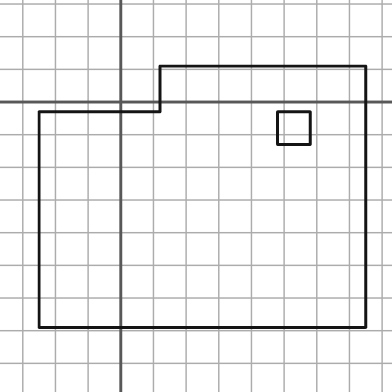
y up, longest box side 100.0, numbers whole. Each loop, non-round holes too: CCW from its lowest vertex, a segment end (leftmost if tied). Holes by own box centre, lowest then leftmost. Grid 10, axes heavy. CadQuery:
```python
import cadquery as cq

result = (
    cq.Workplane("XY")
    .moveTo(-25.0, -69.0)
    .lineTo(75.0, -69.0)
    .lineTo(75.0, 11.0)
    .lineTo(12.0, 11.0)
    .lineTo(12.0, -3.0)
    .lineTo(-25.0, -3.0)
    .close()
    .moveTo(48.0, -13.0)
    .lineTo(58.0, -13.0)
    .lineTo(58.0, -3.0)
    .lineTo(48.0, -3.0)
    .close()
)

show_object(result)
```